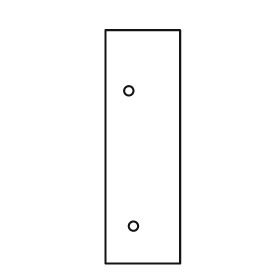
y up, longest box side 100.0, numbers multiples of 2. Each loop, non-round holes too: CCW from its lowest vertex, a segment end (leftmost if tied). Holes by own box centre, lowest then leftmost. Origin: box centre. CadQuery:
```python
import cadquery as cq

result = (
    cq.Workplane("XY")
    .moveTo(-16.0, -50.0)
    .lineTo(16.0, -50.0)
    .lineTo(16.0, 50.0)
    .lineTo(-16.0, 50.0)
    .close()
    .moveTo(-4.0, -34.0)
    .circle(2.0)
    .moveTo(-6.0, 24.0)
    .circle(2.0)
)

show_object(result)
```